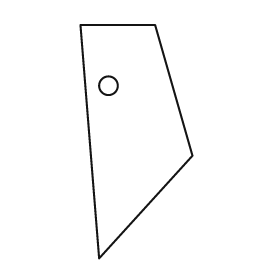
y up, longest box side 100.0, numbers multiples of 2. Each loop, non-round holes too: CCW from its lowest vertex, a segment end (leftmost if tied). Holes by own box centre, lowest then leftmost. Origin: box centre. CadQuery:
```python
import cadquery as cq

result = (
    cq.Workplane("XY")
    .moveTo(-16.0, -50.0)
    .lineTo(24.0, -6.0)
    .lineTo(8.0, 50.0)
    .lineTo(-24.0, 50.0)
    .close()
    .moveTo(-12.0, 24.0)
    .circle(4.0)
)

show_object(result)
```